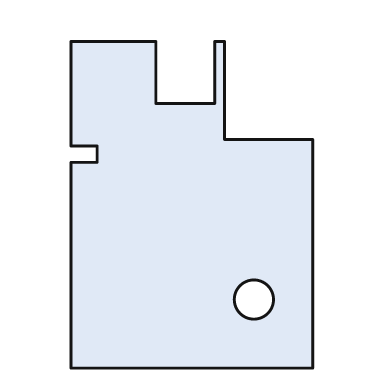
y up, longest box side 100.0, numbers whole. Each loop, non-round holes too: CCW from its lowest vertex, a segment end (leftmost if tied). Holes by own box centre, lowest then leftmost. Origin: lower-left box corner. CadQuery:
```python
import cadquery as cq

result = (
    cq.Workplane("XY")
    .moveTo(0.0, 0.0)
    .lineTo(74.0, 0.0)
    .lineTo(74.0, 70.0)
    .lineTo(47.0, 70.0)
    .lineTo(47.0, 100.0)
    .lineTo(44.0, 100.0)
    .lineTo(44.0, 81.0)
    .lineTo(26.0, 81.0)
    .lineTo(26.0, 100.0)
    .lineTo(0.0, 100.0)
    .lineTo(0.0, 68.0)
    .lineTo(8.0, 68.0)
    .lineTo(8.0, 63.0)
    .lineTo(0.0, 63.0)
    .close()
    .moveTo(56.0, 21.0)
    .circle(6.0)
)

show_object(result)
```